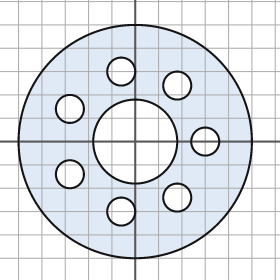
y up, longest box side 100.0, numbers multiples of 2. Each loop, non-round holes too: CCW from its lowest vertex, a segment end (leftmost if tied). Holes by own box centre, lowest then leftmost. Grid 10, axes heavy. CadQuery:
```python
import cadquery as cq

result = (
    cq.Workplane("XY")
    .moveTo(0.0, 0.0)
    .circle(50.0)
    .moveTo(-6.0, -30.0)
    .circle(6.0)
    .moveTo(18.0, -24.0)
    .circle(6.0)
    .moveTo(-28.0, -14.0)
    .circle(6.0)
    .moveTo(0.0, 0.0)
    .circle(18.0)
    .moveTo(30.0, 0.0)
    .circle(6.0)
    .moveTo(-28.0, 14.0)
    .circle(6.0)
    .moveTo(18.0, 24.0)
    .circle(6.0)
    .moveTo(-6.0, 30.0)
    .circle(6.0)
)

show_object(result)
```